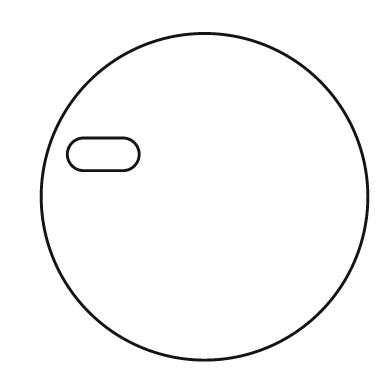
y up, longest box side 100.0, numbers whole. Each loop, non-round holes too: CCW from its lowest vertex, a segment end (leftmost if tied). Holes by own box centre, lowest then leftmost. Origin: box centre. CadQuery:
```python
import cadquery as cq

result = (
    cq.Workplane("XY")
    .moveTo(0.0, 0.0)
    .circle(50.0)
    .moveTo(-37.0, 8.0)
    .lineTo(-25.0, 8.0)
    .threePointArc((-20.0, 13.0), (-25.0, 18.0))
    .lineTo(-37.0, 18.0)
    .threePointArc((-42.0, 13.0), (-37.0, 8.0))
    .close()
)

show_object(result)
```